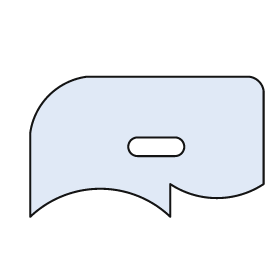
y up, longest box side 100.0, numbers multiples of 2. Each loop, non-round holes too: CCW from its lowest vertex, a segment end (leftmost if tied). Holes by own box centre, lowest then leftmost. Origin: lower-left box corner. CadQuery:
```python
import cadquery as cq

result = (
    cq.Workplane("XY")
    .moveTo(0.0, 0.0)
    .threePointArc((30.0, 12.0), (60.0, 0.0))
    .lineTo(60.0, 14.0)
    .threePointArc((80.0, 8.0), (100.0, 14.0))
    .lineTo(100.0, 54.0)
    .threePointArc((98.0, 58.0), (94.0, 60.0))
    .lineTo(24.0, 60.0)
    .threePointArc((8.0, 52.0), (0.0, 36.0))
    .close()
    .moveTo(46.0, 26.0)
    .lineTo(62.0, 26.0)
    .threePointArc((66.0, 30.0), (62.0, 34.0))
    .lineTo(46.0, 34.0)
    .threePointArc((42.0, 30.0), (46.0, 26.0))
    .close()
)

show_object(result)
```